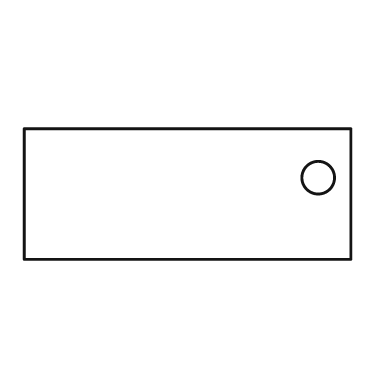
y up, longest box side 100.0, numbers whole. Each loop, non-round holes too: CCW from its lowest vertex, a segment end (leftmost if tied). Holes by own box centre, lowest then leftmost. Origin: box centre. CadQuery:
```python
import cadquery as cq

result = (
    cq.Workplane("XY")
    .moveTo(-50.0, -20.0)
    .lineTo(50.0, -20.0)
    .lineTo(50.0, 20.0)
    .lineTo(-50.0, 20.0)
    .close()
    .moveTo(40.0, 5.0)
    .circle(5.0)
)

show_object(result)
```